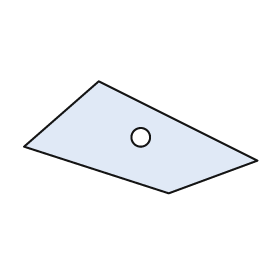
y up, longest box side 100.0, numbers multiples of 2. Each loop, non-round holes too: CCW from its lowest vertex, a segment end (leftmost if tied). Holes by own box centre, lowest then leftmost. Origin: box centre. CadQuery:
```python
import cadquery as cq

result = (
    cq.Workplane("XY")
    .moveTo(12.0, -24.0)
    .lineTo(50.0, -10.0)
    .lineTo(-18.0, 24.0)
    .lineTo(-50.0, -4.0)
    .close()
    .moveTo(0.0, 0.0)
    .circle(4.0)
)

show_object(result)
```